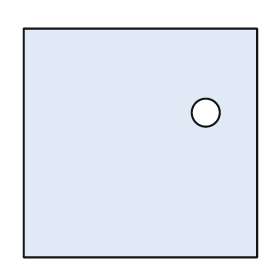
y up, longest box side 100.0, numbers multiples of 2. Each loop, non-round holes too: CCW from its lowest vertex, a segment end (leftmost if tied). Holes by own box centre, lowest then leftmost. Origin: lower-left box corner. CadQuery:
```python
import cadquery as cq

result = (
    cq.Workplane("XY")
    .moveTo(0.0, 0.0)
    .lineTo(100.0, 0.0)
    .lineTo(100.0, 98.0)
    .lineTo(0.0, 98.0)
    .close()
    .moveTo(78.0, 62.0)
    .circle(6.0)
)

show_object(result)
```